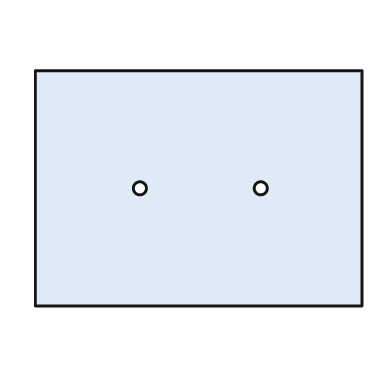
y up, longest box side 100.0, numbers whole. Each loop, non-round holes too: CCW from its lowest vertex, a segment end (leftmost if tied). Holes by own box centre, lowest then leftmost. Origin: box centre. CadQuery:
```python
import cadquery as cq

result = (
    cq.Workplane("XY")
    .moveTo(-50.0, -36.0)
    .lineTo(50.0, -36.0)
    .lineTo(50.0, 36.0)
    .lineTo(-50.0, 36.0)
    .close()
    .moveTo(-18.0, 0.0)
    .circle(2.0)
    .moveTo(19.0, 0.0)
    .circle(2.0)
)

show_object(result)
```